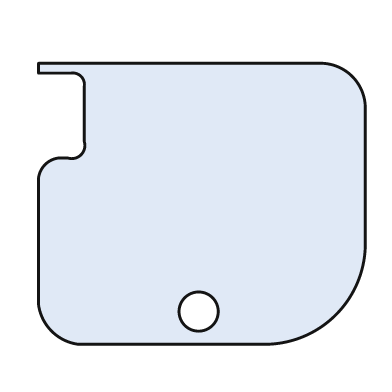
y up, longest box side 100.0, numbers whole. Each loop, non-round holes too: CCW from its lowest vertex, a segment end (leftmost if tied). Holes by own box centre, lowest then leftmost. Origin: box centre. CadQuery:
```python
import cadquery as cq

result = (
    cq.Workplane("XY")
    .moveTo(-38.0, -43.0)
    .lineTo(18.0, -43.0)
    .threePointArc((41.0, -34.0), (50.0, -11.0))
    .lineTo(50.0, 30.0)
    .threePointArc((46.0, 39.0), (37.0, 43.0))
    .lineTo(-50.0, 43.0)
    .lineTo(-50.0, 40.0)
    .lineTo(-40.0, 40.0)
    .threePointArc((-37.0, 39.0), (-36.0, 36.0))
    .lineTo(-36.0, 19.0)
    .threePointArc((-37.0, 15.0), (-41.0, 14.0))
    .lineTo(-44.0, 14.0)
    .threePointArc((-48.0, 12.0), (-50.0, 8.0))
    .lineTo(-50.0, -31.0)
    .threePointArc((-46.0, -39.0), (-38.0, -43.0))
    .close()
    .moveTo(-1.0, -33.0)
    .circle(6.0)
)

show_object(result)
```